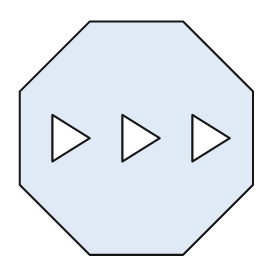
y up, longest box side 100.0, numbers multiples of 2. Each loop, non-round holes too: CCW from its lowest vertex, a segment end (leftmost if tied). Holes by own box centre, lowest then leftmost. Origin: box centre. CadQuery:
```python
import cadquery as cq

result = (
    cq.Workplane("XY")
    .moveTo(-20.0, -50.0)
    .lineTo(20.0, -50.0)
    .lineTo(50.0, -20.0)
    .lineTo(50.0, 20.0)
    .lineTo(20.0, 50.0)
    .lineTo(-20.0, 50.0)
    .lineTo(-50.0, 20.0)
    .lineTo(-50.0, -20.0)
    .close()
    .moveTo(-36.0, -10.0)
    .lineTo(-20.0, 0.0)
    .lineTo(-36.0, 10.0)
    .close()
    .moveTo(-6.0, -10.0)
    .lineTo(10.0, 0.0)
    .lineTo(-6.0, 10.0)
    .close()
    .moveTo(24.0, -10.0)
    .lineTo(40.0, 0.0)
    .lineTo(24.0, 10.0)
    .close()
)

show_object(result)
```